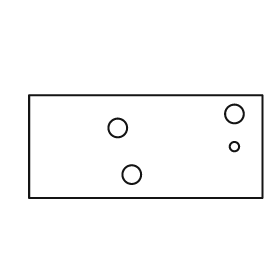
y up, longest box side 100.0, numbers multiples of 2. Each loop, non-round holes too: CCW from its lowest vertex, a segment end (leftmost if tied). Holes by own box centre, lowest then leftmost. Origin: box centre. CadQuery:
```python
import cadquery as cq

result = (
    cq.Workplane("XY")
    .moveTo(-50.0, -22.0)
    .lineTo(50.0, -22.0)
    .lineTo(50.0, 22.0)
    .lineTo(-50.0, 22.0)
    .close()
    .moveTo(-6.0, -12.0)
    .circle(4.0)
    .moveTo(38.0, 0.0)
    .circle(2.0)
    .moveTo(-12.0, 8.0)
    .circle(4.0)
    .moveTo(38.0, 14.0)
    .circle(4.0)
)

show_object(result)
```